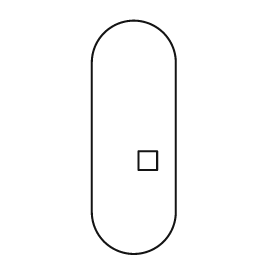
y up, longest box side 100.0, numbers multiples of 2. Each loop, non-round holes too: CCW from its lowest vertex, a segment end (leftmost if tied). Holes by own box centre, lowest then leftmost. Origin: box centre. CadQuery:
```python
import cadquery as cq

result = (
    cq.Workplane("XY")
    .moveTo(-18.0, -32.0)
    .threePointArc((0.0, -50.0), (18.0, -32.0))
    .lineTo(18.0, 32.0)
    .threePointArc((0.0, 50.0), (-18.0, 32.0))
    .close()
    .moveTo(2.0, -14.0)
    .lineTo(10.0, -14.0)
    .lineTo(10.0, -6.0)
    .lineTo(2.0, -6.0)
    .close()
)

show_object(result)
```